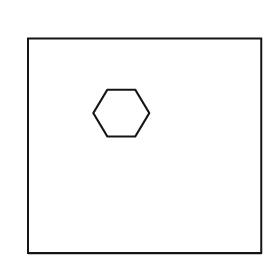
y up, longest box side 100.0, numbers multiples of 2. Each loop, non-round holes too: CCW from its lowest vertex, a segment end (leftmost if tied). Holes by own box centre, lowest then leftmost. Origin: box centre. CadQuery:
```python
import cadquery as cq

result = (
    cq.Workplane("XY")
    .moveTo(-50.0, -46.0)
    .lineTo(50.0, -46.0)
    .lineTo(50.0, 46.0)
    .lineTo(-50.0, 46.0)
    .close()
    .moveTo(-16.0, 4.0)
    .lineTo(-4.0, 4.0)
    .lineTo(2.0, 14.0)
    .lineTo(-4.0, 24.0)
    .lineTo(-16.0, 24.0)
    .lineTo(-22.0, 14.0)
    .close()
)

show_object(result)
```